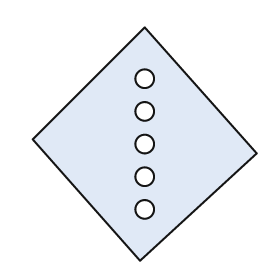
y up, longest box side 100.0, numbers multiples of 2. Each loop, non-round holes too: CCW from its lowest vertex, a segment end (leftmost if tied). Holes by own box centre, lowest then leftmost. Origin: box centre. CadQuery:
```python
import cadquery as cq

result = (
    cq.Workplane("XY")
    .moveTo(-2.0, -50.0)
    .lineTo(48.0, -4.0)
    .lineTo(0.0, 50.0)
    .lineTo(-48.0, 2.0)
    .close()
    .moveTo(0.0, -28.0)
    .circle(4.0)
    .moveTo(0.0, -14.0)
    .circle(4.0)
    .moveTo(0.0, 0.0)
    .circle(4.0)
    .moveTo(0.0, 14.0)
    .circle(4.0)
    .moveTo(0.0, 28.0)
    .circle(4.0)
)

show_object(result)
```